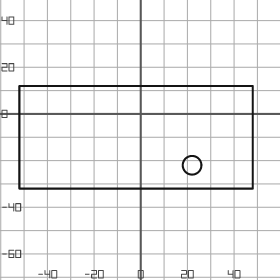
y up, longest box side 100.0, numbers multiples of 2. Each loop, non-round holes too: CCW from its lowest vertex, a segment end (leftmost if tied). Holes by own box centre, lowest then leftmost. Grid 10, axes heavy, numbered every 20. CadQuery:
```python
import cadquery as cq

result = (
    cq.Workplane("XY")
    .moveTo(-52.0, -32.0)
    .lineTo(48.0, -32.0)
    .lineTo(48.0, 12.0)
    .lineTo(-52.0, 12.0)
    .close()
    .moveTo(22.0, -22.0)
    .circle(4.0)
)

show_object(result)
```